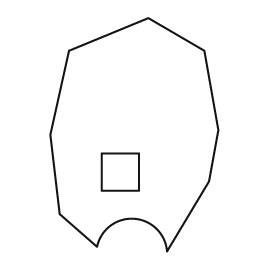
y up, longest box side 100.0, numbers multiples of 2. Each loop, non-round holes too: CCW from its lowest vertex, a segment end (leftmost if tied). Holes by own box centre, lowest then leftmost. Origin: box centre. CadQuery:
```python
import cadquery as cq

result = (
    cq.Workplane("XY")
    .moveTo(14.0, -50.0)
    .lineTo(32.0, -20.0)
    .lineTo(36.0, 2.0)
    .lineTo(30.0, 36.0)
    .lineTo(6.0, 50.0)
    .lineTo(-28.0, 36.0)
    .lineTo(-36.0, 0.0)
    .lineTo(-32.0, -34.0)
    .lineTo(-16.0, -48.0)
    .threePointArc((0.0, -36.0), (14.0, -50.0))
    .close()
    .moveTo(-14.0, -24.0)
    .lineTo(2.0, -24.0)
    .lineTo(2.0, -8.0)
    .lineTo(-14.0, -8.0)
    .close()
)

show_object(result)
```